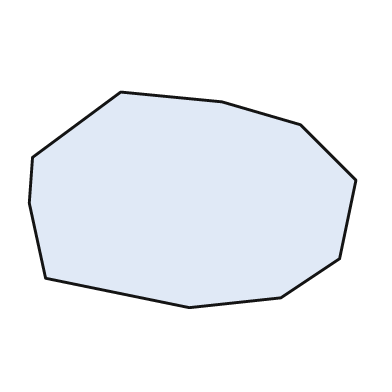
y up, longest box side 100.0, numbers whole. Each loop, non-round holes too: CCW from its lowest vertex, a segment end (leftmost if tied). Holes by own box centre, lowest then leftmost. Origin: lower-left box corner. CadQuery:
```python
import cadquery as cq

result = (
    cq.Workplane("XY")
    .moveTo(49.0, 0.0)
    .lineTo(77.0, 3.0)
    .lineTo(95.0, 15.0)
    .lineTo(100.0, 39.0)
    .lineTo(83.0, 56.0)
    .lineTo(59.0, 63.0)
    .lineTo(28.0, 66.0)
    .lineTo(1.0, 46.0)
    .lineTo(0.0, 32.0)
    .lineTo(5.0, 9.0)
    .close()
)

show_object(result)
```